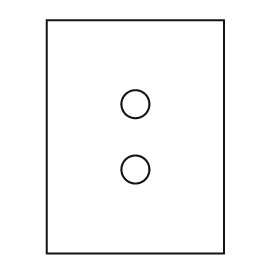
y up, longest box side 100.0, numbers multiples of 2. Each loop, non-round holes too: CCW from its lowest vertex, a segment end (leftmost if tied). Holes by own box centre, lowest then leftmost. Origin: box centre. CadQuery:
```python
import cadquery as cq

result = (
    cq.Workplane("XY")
    .moveTo(-38.0, -50.0)
    .lineTo(38.0, -50.0)
    .lineTo(38.0, 50.0)
    .lineTo(-38.0, 50.0)
    .close()
    .moveTo(0.0, -14.0)
    .circle(6.0)
    .moveTo(0.0, 14.0)
    .circle(6.0)
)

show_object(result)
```